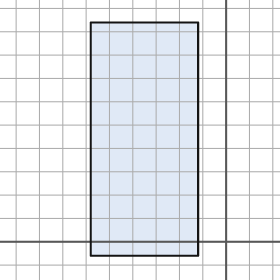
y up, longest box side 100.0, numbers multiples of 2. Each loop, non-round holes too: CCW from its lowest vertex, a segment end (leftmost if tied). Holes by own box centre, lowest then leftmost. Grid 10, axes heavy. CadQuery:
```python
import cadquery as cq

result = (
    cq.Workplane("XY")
    .moveTo(-58.0, -6.0)
    .lineTo(-12.0, -6.0)
    .lineTo(-12.0, 94.0)
    .lineTo(-58.0, 94.0)
    .close()
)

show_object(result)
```